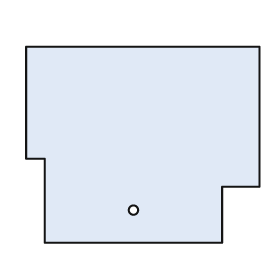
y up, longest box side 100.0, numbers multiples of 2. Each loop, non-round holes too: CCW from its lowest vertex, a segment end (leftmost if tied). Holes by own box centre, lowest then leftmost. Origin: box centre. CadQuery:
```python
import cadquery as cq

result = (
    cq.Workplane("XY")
    .moveTo(-42.0, -42.0)
    .lineTo(34.0, -42.0)
    .lineTo(34.0, -18.0)
    .lineTo(50.0, -18.0)
    .lineTo(50.0, 42.0)
    .lineTo(-50.0, 42.0)
    .lineTo(-50.0, -6.0)
    .lineTo(-42.0, -6.0)
    .close()
    .moveTo(-4.0, -28.0)
    .circle(2.0)
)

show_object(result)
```